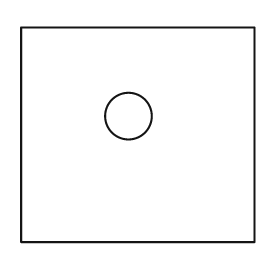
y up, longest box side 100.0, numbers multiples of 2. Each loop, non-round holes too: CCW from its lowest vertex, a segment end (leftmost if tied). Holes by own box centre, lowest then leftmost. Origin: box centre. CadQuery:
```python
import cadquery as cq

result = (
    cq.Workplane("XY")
    .moveTo(-50.0, -46.0)
    .lineTo(50.0, -46.0)
    .lineTo(50.0, 46.0)
    .lineTo(-50.0, 46.0)
    .close()
    .moveTo(-4.0, 8.0)
    .circle(10.0)
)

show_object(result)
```